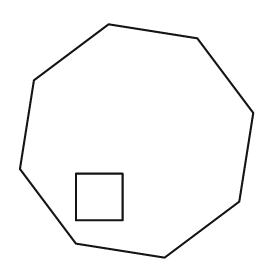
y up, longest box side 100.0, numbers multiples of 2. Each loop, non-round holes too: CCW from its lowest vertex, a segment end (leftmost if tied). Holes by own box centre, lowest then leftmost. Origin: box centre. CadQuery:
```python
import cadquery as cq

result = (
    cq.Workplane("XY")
    .moveTo(12.0, -50.0)
    .lineTo(44.0, -26.0)
    .lineTo(50.0, 12.0)
    .lineTo(26.0, 44.0)
    .lineTo(-12.0, 50.0)
    .lineTo(-44.0, 26.0)
    .lineTo(-50.0, -12.0)
    .lineTo(-26.0, -44.0)
    .close()
    .moveTo(-26.0, -34.0)
    .lineTo(-6.0, -34.0)
    .lineTo(-6.0, -14.0)
    .lineTo(-26.0, -14.0)
    .close()
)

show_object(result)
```